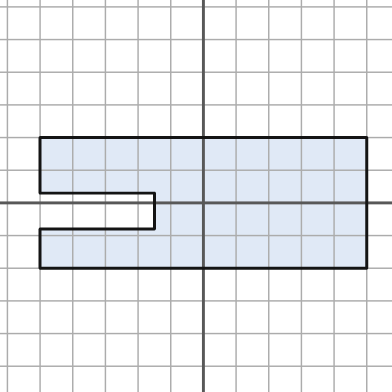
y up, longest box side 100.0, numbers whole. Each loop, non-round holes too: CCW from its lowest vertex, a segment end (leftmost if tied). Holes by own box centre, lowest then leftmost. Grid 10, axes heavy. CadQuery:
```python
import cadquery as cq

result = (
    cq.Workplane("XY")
    .moveTo(-50.0, -20.0)
    .lineTo(50.0, -20.0)
    .lineTo(50.0, 20.0)
    .lineTo(-50.0, 20.0)
    .lineTo(-50.0, 3.0)
    .lineTo(-15.0, 3.0)
    .lineTo(-15.0, -8.0)
    .lineTo(-50.0, -8.0)
    .close()
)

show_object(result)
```